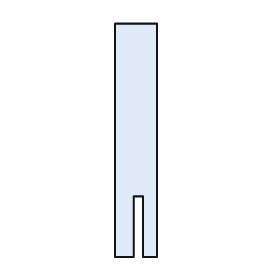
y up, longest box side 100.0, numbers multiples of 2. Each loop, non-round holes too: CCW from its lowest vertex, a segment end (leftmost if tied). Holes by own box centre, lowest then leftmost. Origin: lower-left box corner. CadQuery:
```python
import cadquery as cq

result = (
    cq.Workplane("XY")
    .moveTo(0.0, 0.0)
    .lineTo(8.0, 0.0)
    .lineTo(8.0, 26.0)
    .lineTo(12.0, 26.0)
    .lineTo(12.0, 0.0)
    .lineTo(18.0, 0.0)
    .lineTo(18.0, 100.0)
    .lineTo(0.0, 100.0)
    .close()
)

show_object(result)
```